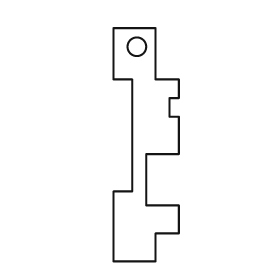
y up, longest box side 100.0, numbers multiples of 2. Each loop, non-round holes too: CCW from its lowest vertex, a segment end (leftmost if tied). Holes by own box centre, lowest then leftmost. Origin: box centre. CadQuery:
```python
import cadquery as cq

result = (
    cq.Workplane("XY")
    .moveTo(-14.0, -50.0)
    .lineTo(4.0, -50.0)
    .lineTo(4.0, -38.0)
    .lineTo(14.0, -38.0)
    .lineTo(14.0, -26.0)
    .lineTo(0.0, -26.0)
    .lineTo(0.0, -4.0)
    .lineTo(14.0, -4.0)
    .lineTo(14.0, 12.0)
    .lineTo(10.0, 12.0)
    .lineTo(10.0, 20.0)
    .lineTo(14.0, 20.0)
    .lineTo(14.0, 28.0)
    .lineTo(4.0, 28.0)
    .lineTo(4.0, 50.0)
    .lineTo(-14.0, 50.0)
    .lineTo(-14.0, 28.0)
    .lineTo(-6.0, 28.0)
    .lineTo(-6.0, -20.0)
    .lineTo(-14.0, -20.0)
    .close()
    .moveTo(-4.0, 42.0)
    .circle(4.0)
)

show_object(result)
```